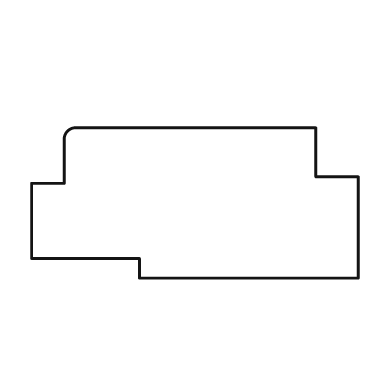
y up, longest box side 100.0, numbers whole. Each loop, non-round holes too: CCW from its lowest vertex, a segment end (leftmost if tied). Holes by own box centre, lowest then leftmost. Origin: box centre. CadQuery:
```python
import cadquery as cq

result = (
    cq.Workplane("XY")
    .moveTo(-17.0, -23.0)
    .lineTo(50.0, -23.0)
    .lineTo(50.0, 8.0)
    .lineTo(37.0, 8.0)
    .lineTo(37.0, 23.0)
    .lineTo(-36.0, 23.0)
    .threePointArc((-39.0, 22.0), (-40.0, 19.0))
    .lineTo(-40.0, 6.0)
    .lineTo(-50.0, 6.0)
    .lineTo(-50.0, -17.0)
    .lineTo(-17.0, -17.0)
    .close()
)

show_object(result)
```